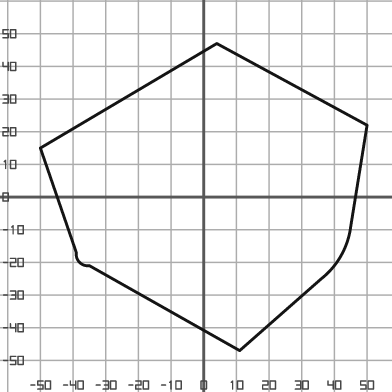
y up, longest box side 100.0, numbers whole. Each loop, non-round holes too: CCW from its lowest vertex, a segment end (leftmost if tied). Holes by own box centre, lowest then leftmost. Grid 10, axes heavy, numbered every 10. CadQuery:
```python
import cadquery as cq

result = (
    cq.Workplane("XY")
    .moveTo(11.0, -47.0)
    .lineTo(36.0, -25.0)
    .threePointArc((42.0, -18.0), (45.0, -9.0))
    .lineTo(50.0, 22.0)
    .lineTo(4.0, 47.0)
    .lineTo(-50.0, 15.0)
    .lineTo(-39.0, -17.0)
    .threePointArc((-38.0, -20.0), (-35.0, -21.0))
    .close()
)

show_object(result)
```